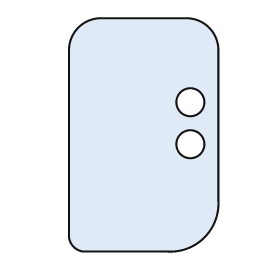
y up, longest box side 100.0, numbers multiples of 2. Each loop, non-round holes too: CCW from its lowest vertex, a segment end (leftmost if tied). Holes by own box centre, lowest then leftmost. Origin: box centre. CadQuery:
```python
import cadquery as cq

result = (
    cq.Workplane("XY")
    .moveTo(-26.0, -50.0)
    .lineTo(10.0, -50.0)
    .threePointArc((26.0, -44.0), (32.0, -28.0))
    .lineTo(32.0, 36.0)
    .threePointArc((28.0, 46.0), (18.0, 50.0))
    .lineTo(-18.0, 50.0)
    .threePointArc((-28.0, 46.0), (-32.0, 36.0))
    .lineTo(-32.0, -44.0)
    .threePointArc((-30.0, -48.0), (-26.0, -50.0))
    .close()
    .moveTo(20.0, -4.0)
    .circle(6.0)
    .moveTo(20.0, 14.0)
    .circle(6.0)
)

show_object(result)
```